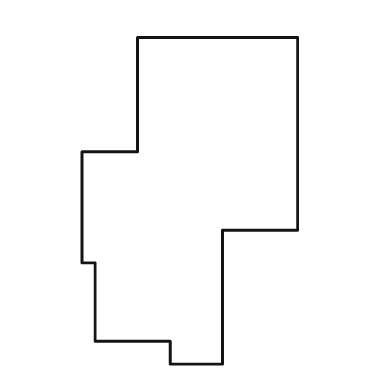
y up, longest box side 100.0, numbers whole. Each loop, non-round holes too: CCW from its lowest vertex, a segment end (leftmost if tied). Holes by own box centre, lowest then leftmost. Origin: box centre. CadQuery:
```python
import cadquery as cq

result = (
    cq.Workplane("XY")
    .moveTo(-6.0, -50.0)
    .lineTo(10.0, -50.0)
    .lineTo(10.0, -9.0)
    .lineTo(33.0, -9.0)
    .lineTo(33.0, 50.0)
    .lineTo(-16.0, 50.0)
    .lineTo(-16.0, 15.0)
    .lineTo(-33.0, 15.0)
    .lineTo(-33.0, -19.0)
    .lineTo(-29.0, -19.0)
    .lineTo(-29.0, -43.0)
    .lineTo(-6.0, -43.0)
    .close()
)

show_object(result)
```